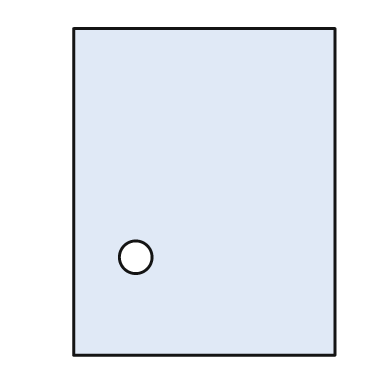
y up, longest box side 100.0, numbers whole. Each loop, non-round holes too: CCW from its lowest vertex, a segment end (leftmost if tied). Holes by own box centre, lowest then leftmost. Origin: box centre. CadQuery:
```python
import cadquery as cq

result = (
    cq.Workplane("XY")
    .moveTo(-40.0, -50.0)
    .lineTo(40.0, -50.0)
    .lineTo(40.0, 50.0)
    .lineTo(-40.0, 50.0)
    .close()
    .moveTo(-21.0, -20.0)
    .circle(5.0)
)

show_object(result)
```